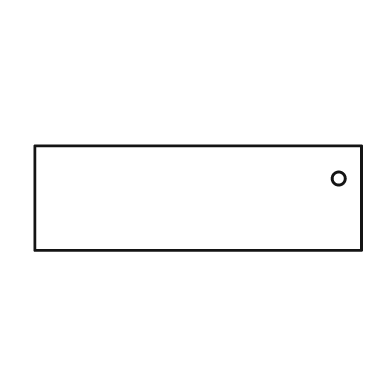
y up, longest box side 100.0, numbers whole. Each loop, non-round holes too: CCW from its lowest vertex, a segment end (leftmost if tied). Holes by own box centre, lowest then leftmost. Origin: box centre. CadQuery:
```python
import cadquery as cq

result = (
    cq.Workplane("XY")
    .moveTo(-50.0, -16.0)
    .lineTo(50.0, -16.0)
    .lineTo(50.0, 16.0)
    .lineTo(-50.0, 16.0)
    .close()
    .moveTo(43.0, 6.0)
    .circle(2.0)
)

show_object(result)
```